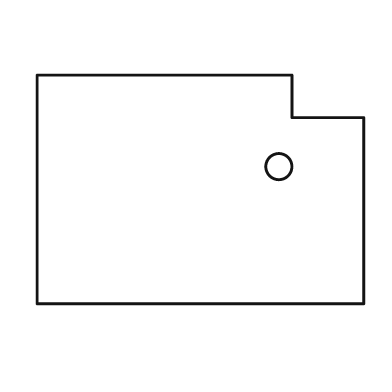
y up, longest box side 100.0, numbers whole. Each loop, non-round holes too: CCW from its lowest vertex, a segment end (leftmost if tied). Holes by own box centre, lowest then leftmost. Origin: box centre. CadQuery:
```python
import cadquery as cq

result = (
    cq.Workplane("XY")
    .moveTo(-50.0, -35.0)
    .lineTo(50.0, -35.0)
    .lineTo(50.0, 22.0)
    .lineTo(28.0, 22.0)
    .lineTo(28.0, 35.0)
    .lineTo(-50.0, 35.0)
    .close()
    .moveTo(24.0, 7.0)
    .circle(4.0)
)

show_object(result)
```